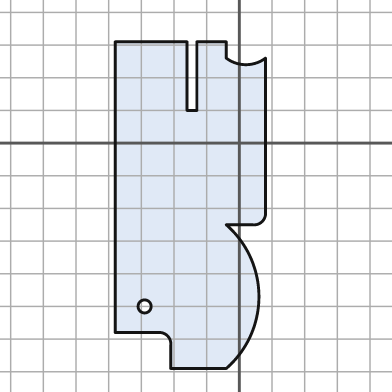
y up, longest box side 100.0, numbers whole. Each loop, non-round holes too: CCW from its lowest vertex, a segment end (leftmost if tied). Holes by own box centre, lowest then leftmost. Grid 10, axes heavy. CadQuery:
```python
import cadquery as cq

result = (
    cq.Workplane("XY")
    .moveTo(-21.0, -69.0)
    .lineTo(-4.0, -69.0)
    .threePointArc((6.0, -47.0), (-4.0, -25.0))
    .lineTo(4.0, -25.0)
    .threePointArc((7.0, -24.0), (8.0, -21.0))
    .lineTo(8.0, 26.0)
    .threePointArc((2.0, 24.0), (-4.0, 26.0))
    .lineTo(-4.0, 31.0)
    .lineTo(-13.0, 31.0)
    .lineTo(-13.0, 10.0)
    .lineTo(-16.0, 10.0)
    .lineTo(-16.0, 31.0)
    .lineTo(-38.0, 31.0)
    .lineTo(-38.0, -58.0)
    .lineTo(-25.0, -58.0)
    .threePointArc((-22.0, -59.0), (-21.0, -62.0))
    .close()
    .moveTo(-29.0, -50.0)
    .circle(2.0)
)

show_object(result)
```